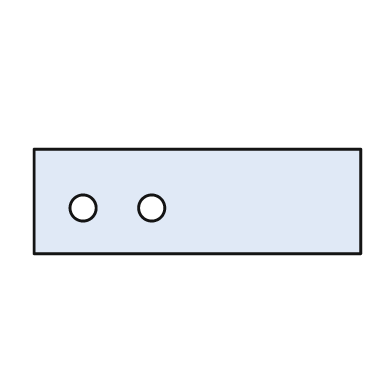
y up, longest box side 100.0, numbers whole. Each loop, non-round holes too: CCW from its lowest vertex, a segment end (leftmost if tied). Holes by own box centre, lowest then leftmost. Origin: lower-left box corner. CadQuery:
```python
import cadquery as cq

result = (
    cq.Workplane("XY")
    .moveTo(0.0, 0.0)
    .lineTo(100.0, 0.0)
    .lineTo(100.0, 32.0)
    .lineTo(0.0, 32.0)
    .close()
    .moveTo(15.0, 14.0)
    .circle(4.0)
    .moveTo(36.0, 14.0)
    .circle(4.0)
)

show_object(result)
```